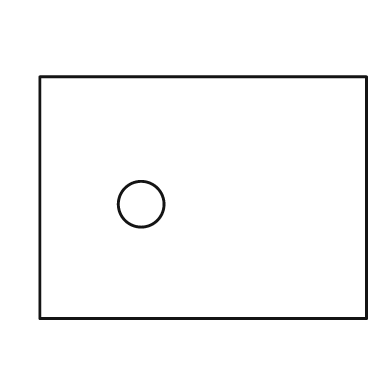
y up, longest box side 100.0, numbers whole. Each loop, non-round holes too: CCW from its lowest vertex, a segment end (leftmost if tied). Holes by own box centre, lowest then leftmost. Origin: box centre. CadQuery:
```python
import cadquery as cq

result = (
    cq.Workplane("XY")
    .moveTo(-50.0, -37.0)
    .lineTo(50.0, -37.0)
    .lineTo(50.0, 37.0)
    .lineTo(-50.0, 37.0)
    .close()
    .moveTo(-19.0, -2.0)
    .circle(7.0)
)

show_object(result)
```